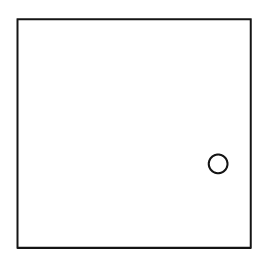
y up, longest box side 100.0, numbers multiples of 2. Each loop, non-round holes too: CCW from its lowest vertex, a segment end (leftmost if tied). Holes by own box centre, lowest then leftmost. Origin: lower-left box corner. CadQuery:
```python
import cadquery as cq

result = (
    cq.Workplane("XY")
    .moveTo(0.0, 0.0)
    .lineTo(100.0, 0.0)
    .lineTo(100.0, 98.0)
    .lineTo(0.0, 98.0)
    .close()
    .moveTo(86.0, 36.0)
    .circle(4.0)
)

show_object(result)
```